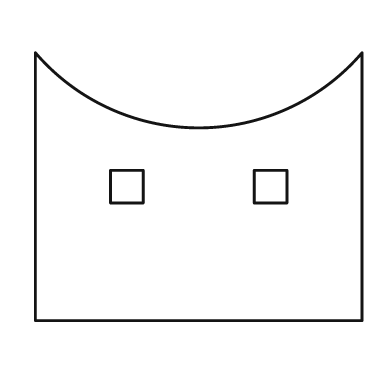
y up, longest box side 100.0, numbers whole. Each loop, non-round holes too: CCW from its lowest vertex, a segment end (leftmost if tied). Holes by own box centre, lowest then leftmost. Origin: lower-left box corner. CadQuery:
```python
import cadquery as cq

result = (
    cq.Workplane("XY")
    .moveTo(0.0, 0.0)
    .lineTo(100.0, 0.0)
    .lineTo(100.0, 82.0)
    .threePointArc((50.0, 59.0), (0.0, 82.0))
    .close()
    .moveTo(23.0, 36.0)
    .lineTo(33.0, 36.0)
    .lineTo(33.0, 46.0)
    .lineTo(23.0, 46.0)
    .close()
    .moveTo(67.0, 36.0)
    .lineTo(77.0, 36.0)
    .lineTo(77.0, 46.0)
    .lineTo(67.0, 46.0)
    .close()
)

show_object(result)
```